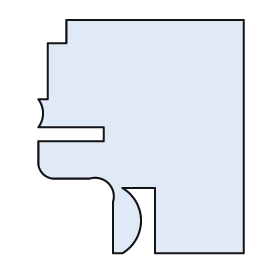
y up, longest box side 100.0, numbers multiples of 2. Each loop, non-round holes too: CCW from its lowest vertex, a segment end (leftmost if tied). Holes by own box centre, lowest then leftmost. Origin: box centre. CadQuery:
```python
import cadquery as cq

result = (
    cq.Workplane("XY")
    .moveTo(-12.0, -50.0)
    .lineTo(-8.0, -50.0)
    .threePointArc((0.0, -36.0), (-8.0, -22.0))
    .lineTo(6.0, -22.0)
    .lineTo(6.0, -50.0)
    .lineTo(44.0, -50.0)
    .lineTo(44.0, 50.0)
    .lineTo(-32.0, 50.0)
    .lineTo(-32.0, 40.0)
    .lineTo(-40.0, 40.0)
    .lineTo(-40.0, 16.0)
    .lineTo(-44.0, 16.0)
    .threePointArc((-42.0, 10.0), (-44.0, 4.0))
    .lineTo(-16.0, 4.0)
    .lineTo(-16.0, -2.0)
    .lineTo(-44.0, -2.0)
    .lineTo(-44.0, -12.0)
    .threePointArc((-42.0, -16.0), (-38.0, -18.0))
    .lineTo(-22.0, -18.0)
    .threePointArc((-14.0, -20.0), (-12.0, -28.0))
    .close()
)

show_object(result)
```